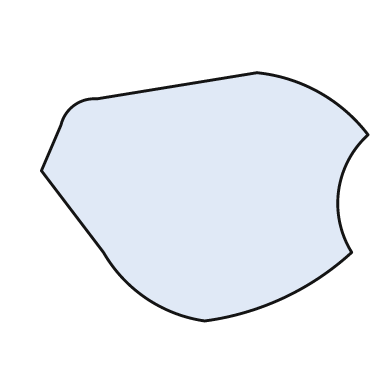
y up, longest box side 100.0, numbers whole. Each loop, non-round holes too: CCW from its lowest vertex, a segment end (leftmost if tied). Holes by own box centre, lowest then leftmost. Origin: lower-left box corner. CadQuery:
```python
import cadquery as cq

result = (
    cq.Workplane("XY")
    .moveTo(50.0, 0.0)
    .threePointArc((74.0, 7.0), (95.0, 21.0))
    .threePointArc((91.0, 40.0), (100.0, 57.0))
    .threePointArc((85.0, 70.0), (66.0, 76.0))
    .lineTo(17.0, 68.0)
    .threePointArc((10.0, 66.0), (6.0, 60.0))
    .lineTo(0.0, 46.0)
    .lineTo(19.0, 21.0)
    .threePointArc((32.0, 7.0), (50.0, 0.0))
    .close()
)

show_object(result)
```